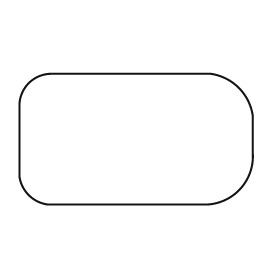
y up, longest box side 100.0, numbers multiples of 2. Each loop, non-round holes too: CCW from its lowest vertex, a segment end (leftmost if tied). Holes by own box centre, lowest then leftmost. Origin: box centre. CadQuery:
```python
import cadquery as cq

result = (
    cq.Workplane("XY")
    .moveTo(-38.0, -28.0)
    .lineTo(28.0, -28.0)
    .threePointArc((44.0, -22.0), (50.0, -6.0))
    .lineTo(50.0, 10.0)
    .threePointArc((44.0, 22.0), (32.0, 28.0))
    .lineTo(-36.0, 28.0)
    .threePointArc((-46.0, 24.0), (-50.0, 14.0))
    .lineTo(-50.0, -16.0)
    .threePointArc((-46.0, -24.0), (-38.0, -28.0))
    .close()
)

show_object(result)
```